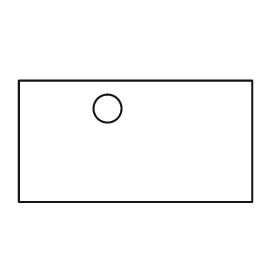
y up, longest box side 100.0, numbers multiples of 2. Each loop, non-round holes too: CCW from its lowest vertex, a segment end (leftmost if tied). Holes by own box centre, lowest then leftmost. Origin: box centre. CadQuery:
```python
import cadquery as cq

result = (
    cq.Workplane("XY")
    .moveTo(-50.0, -26.0)
    .lineTo(50.0, -26.0)
    .lineTo(50.0, 26.0)
    .lineTo(-50.0, 26.0)
    .close()
    .moveTo(-12.0, 14.0)
    .circle(6.0)
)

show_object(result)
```